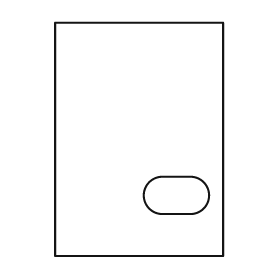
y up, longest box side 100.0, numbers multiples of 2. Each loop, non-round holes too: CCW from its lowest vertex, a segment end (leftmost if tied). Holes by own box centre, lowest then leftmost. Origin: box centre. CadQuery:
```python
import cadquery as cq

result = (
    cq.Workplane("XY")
    .moveTo(-36.0, -50.0)
    .lineTo(36.0, -50.0)
    .lineTo(36.0, 50.0)
    .lineTo(-36.0, 50.0)
    .close()
    .moveTo(10.0, -32.0)
    .lineTo(22.0, -32.0)
    .threePointArc((30.0, -24.0), (22.0, -16.0))
    .lineTo(10.0, -16.0)
    .threePointArc((2.0, -24.0), (10.0, -32.0))
    .close()
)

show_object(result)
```